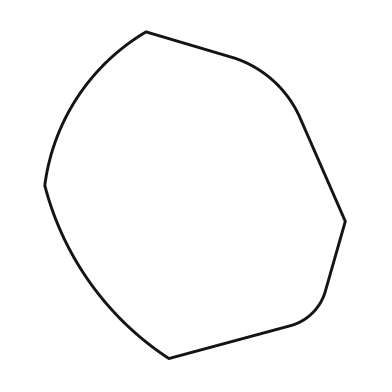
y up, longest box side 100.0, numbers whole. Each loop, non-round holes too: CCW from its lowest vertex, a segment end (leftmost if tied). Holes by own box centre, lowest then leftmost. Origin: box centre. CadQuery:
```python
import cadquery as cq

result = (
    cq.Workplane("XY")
    .moveTo(-8.0, -50.0)
    .lineTo(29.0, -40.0)
    .threePointArc((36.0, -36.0), (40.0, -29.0))
    .lineTo(46.0, -8.0)
    .lineTo(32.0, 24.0)
    .threePointArc((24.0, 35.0), (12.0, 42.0))
    .lineTo(-15.0, 50.0)
    .threePointArc((-36.0, 30.0), (-46.0, 3.0))
    .threePointArc((-32.0, -27.0), (-8.0, -50.0))
    .close()
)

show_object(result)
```